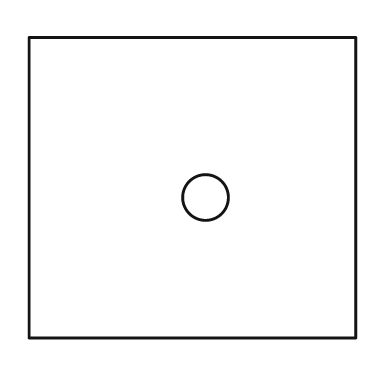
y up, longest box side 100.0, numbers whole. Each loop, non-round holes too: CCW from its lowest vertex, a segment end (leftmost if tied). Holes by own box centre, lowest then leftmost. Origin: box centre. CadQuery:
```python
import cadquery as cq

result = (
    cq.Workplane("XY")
    .moveTo(-50.0, -46.0)
    .lineTo(50.0, -46.0)
    .lineTo(50.0, 46.0)
    .lineTo(-50.0, 46.0)
    .close()
    .moveTo(4.0, -3.0)
    .circle(7.0)
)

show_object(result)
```